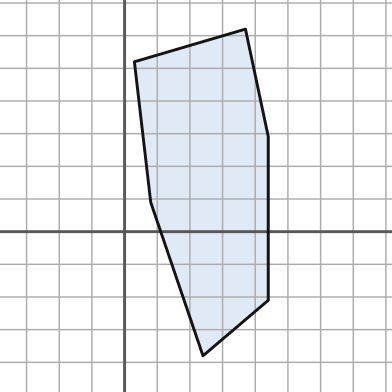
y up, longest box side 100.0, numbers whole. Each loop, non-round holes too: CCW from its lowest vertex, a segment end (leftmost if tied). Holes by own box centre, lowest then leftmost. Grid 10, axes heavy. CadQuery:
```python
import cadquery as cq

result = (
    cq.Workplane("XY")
    .moveTo(24.0, -38.0)
    .lineTo(44.0, -21.0)
    .lineTo(44.0, 29.0)
    .lineTo(37.0, 62.0)
    .lineTo(3.0, 52.0)
    .lineTo(8.0, 9.0)
    .close()
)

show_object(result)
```